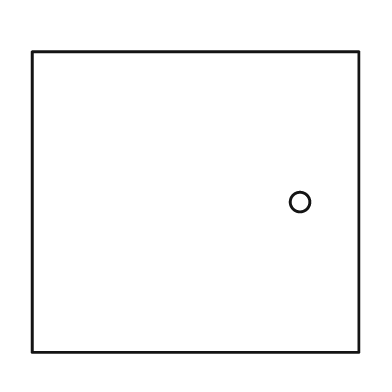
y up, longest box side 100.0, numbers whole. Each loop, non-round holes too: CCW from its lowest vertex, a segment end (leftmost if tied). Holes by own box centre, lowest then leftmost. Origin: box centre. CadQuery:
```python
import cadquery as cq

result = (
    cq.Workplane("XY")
    .moveTo(-50.0, -46.0)
    .lineTo(50.0, -46.0)
    .lineTo(50.0, 46.0)
    .lineTo(-50.0, 46.0)
    .close()
    .moveTo(32.0, 0.0)
    .circle(3.0)
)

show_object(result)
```